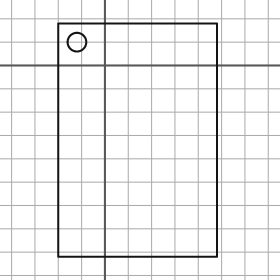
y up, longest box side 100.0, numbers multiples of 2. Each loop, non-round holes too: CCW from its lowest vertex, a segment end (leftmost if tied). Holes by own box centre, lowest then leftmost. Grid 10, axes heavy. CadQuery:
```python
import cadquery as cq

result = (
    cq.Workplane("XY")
    .moveTo(-20.0, -82.0)
    .lineTo(48.0, -82.0)
    .lineTo(48.0, 18.0)
    .lineTo(-20.0, 18.0)
    .close()
    .moveTo(-12.0, 10.0)
    .circle(4.0)
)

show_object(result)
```